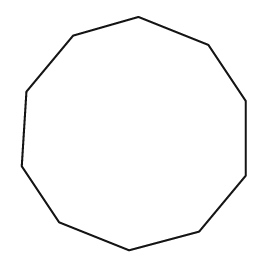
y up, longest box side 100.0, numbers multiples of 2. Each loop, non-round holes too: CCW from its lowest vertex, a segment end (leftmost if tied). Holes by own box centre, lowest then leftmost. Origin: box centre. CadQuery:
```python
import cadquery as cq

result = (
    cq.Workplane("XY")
    .moveTo(-2.0, -50.0)
    .lineTo(28.0, -42.0)
    .lineTo(48.0, -18.0)
    .lineTo(48.0, 14.0)
    .lineTo(32.0, 38.0)
    .lineTo(2.0, 50.0)
    .lineTo(-26.0, 42.0)
    .lineTo(-46.0, 18.0)
    .lineTo(-48.0, -14.0)
    .lineTo(-32.0, -38.0)
    .close()
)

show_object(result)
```